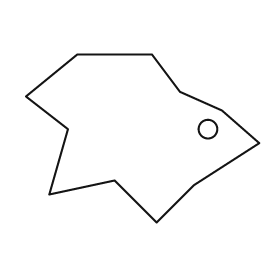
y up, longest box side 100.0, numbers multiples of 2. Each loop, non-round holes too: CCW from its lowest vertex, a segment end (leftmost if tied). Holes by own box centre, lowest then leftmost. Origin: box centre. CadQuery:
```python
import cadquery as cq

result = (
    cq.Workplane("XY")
    .moveTo(6.0, -36.0)
    .lineTo(22.0, -20.0)
    .lineTo(50.0, -2.0)
    .lineTo(34.0, 12.0)
    .lineTo(16.0, 20.0)
    .lineTo(4.0, 36.0)
    .lineTo(-28.0, 36.0)
    .lineTo(-50.0, 18.0)
    .lineTo(-32.0, 4.0)
    .lineTo(-40.0, -24.0)
    .lineTo(-12.0, -18.0)
    .close()
    .moveTo(28.0, 4.0)
    .circle(4.0)
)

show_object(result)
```